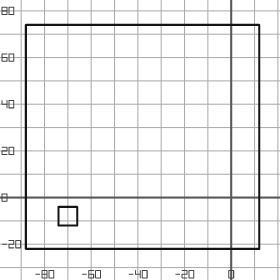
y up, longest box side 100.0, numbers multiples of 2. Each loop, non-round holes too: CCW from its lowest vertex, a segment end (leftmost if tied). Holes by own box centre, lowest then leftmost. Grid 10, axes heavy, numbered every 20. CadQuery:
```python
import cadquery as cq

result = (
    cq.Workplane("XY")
    .moveTo(-88.0, -22.0)
    .lineTo(12.0, -22.0)
    .lineTo(12.0, 74.0)
    .lineTo(-88.0, 74.0)
    .close()
    .moveTo(-74.0, -12.0)
    .lineTo(-66.0, -12.0)
    .lineTo(-66.0, -4.0)
    .lineTo(-74.0, -4.0)
    .close()
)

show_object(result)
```